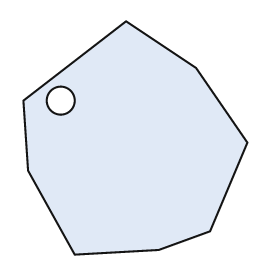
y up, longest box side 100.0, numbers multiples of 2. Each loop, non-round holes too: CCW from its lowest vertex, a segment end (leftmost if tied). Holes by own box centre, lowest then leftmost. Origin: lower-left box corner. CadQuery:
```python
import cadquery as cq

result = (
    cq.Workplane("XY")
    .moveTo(22.0, 0.0)
    .lineTo(58.0, 2.0)
    .lineTo(80.0, 10.0)
    .lineTo(96.0, 48.0)
    .lineTo(74.0, 80.0)
    .lineTo(44.0, 100.0)
    .lineTo(0.0, 66.0)
    .lineTo(2.0, 36.0)
    .close()
    .moveTo(16.0, 66.0)
    .circle(6.0)
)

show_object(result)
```